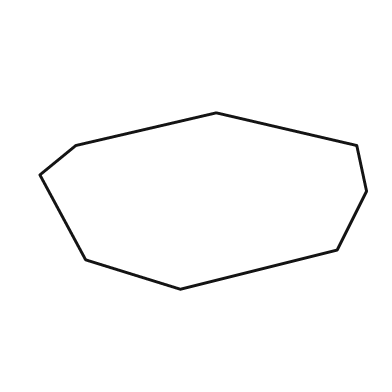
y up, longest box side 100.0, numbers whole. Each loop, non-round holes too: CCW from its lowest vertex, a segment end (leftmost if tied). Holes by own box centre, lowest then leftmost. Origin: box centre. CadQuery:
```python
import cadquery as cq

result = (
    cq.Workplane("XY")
    .moveTo(-7.0, -27.0)
    .lineTo(41.0, -15.0)
    .lineTo(50.0, 3.0)
    .lineTo(47.0, 17.0)
    .lineTo(4.0, 27.0)
    .lineTo(-39.0, 17.0)
    .lineTo(-50.0, 8.0)
    .lineTo(-36.0, -18.0)
    .close()
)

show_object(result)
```